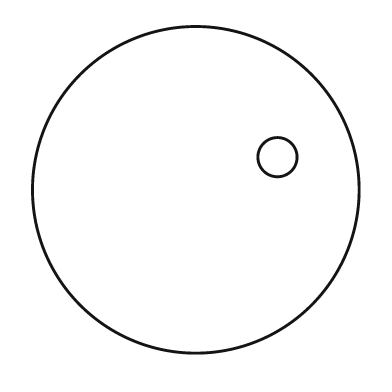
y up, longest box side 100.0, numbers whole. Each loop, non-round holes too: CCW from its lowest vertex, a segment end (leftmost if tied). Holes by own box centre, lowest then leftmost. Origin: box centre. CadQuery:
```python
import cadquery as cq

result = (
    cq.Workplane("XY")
    .moveTo(0.0, 0.0)
    .circle(50.0)
    .moveTo(25.0, 10.0)
    .circle(6.0)
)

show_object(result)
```